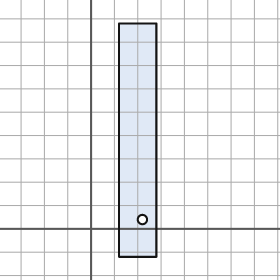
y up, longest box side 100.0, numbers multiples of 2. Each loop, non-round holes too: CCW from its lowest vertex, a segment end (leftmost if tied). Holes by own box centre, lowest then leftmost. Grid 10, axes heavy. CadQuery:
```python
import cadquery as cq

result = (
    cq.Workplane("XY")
    .moveTo(12.0, -12.0)
    .lineTo(28.0, -12.0)
    .lineTo(28.0, 88.0)
    .lineTo(12.0, 88.0)
    .close()
    .moveTo(22.0, 4.0)
    .circle(2.0)
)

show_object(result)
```